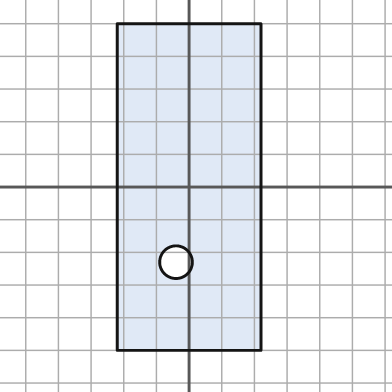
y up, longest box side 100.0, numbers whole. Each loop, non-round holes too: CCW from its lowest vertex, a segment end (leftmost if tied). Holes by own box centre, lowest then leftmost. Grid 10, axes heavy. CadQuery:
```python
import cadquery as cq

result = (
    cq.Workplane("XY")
    .moveTo(-22.0, -50.0)
    .lineTo(22.0, -50.0)
    .lineTo(22.0, 50.0)
    .lineTo(-22.0, 50.0)
    .close()
    .moveTo(-4.0, -23.0)
    .circle(5.0)
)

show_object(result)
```